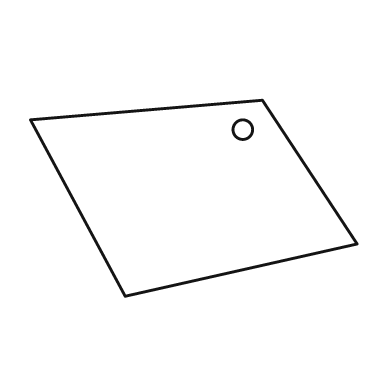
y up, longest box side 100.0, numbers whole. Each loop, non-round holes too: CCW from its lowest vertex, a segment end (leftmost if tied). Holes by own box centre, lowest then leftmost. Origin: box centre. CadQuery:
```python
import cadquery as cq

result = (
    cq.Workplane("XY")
    .moveTo(-21.0, -30.0)
    .lineTo(50.0, -14.0)
    .lineTo(21.0, 30.0)
    .lineTo(-50.0, 24.0)
    .close()
    .moveTo(15.0, 21.0)
    .circle(3.0)
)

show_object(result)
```